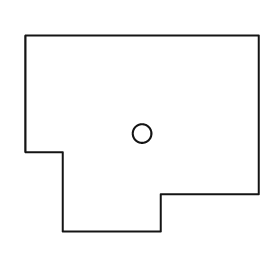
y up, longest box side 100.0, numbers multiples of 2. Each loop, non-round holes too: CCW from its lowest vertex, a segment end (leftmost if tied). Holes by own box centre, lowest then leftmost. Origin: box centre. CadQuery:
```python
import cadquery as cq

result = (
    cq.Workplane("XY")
    .moveTo(-34.0, -42.0)
    .lineTo(8.0, -42.0)
    .lineTo(8.0, -26.0)
    .lineTo(50.0, -26.0)
    .lineTo(50.0, 42.0)
    .lineTo(-50.0, 42.0)
    .lineTo(-50.0, -8.0)
    .lineTo(-34.0, -8.0)
    .close()
    .moveTo(0.0, 0.0)
    .circle(4.0)
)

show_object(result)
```